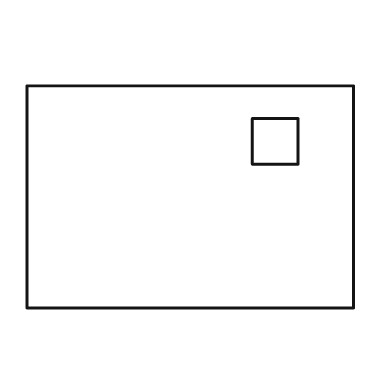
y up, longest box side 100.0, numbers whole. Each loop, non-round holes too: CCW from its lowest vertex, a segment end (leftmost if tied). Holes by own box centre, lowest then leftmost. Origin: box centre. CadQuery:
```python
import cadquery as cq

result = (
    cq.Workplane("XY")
    .moveTo(-50.0, -34.0)
    .lineTo(50.0, -34.0)
    .lineTo(50.0, 34.0)
    .lineTo(-50.0, 34.0)
    .close()
    .moveTo(19.0, 10.0)
    .lineTo(33.0, 10.0)
    .lineTo(33.0, 24.0)
    .lineTo(19.0, 24.0)
    .close()
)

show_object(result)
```